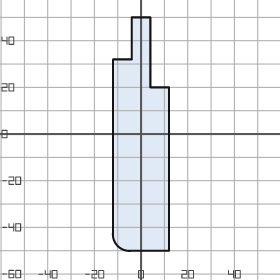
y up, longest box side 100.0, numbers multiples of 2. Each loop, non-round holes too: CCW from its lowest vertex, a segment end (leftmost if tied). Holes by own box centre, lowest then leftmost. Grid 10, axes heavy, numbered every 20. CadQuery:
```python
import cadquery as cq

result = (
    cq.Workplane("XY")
    .moveTo(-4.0, -50.0)
    .lineTo(12.0, -50.0)
    .lineTo(12.0, 20.0)
    .lineTo(4.0, 20.0)
    .lineTo(4.0, 50.0)
    .lineTo(-4.0, 50.0)
    .lineTo(-4.0, 32.0)
    .lineTo(-12.0, 32.0)
    .lineTo(-12.0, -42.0)
    .threePointArc((-10.0, -48.0), (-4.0, -50.0))
    .close()
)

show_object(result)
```